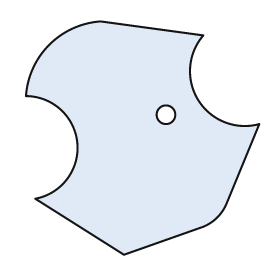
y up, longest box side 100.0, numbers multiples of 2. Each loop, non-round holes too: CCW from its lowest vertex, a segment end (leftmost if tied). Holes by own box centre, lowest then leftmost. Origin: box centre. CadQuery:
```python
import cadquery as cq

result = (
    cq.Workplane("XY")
    .moveTo(-8.0, -50.0)
    .lineTo(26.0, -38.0)
    .threePointArc((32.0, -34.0), (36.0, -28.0))
    .lineTo(50.0, 6.0)
    .threePointArc((24.0, 16.0), (26.0, 44.0))
    .lineTo(-18.0, 50.0)
    .threePointArc((-40.0, 40.0), (-50.0, 18.0))
    .threePointArc((-28.0, -2.0), (-46.0, -26.0))
    .close()
    .moveTo(10.0, 10.0)
    .circle(4.0)
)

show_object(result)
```